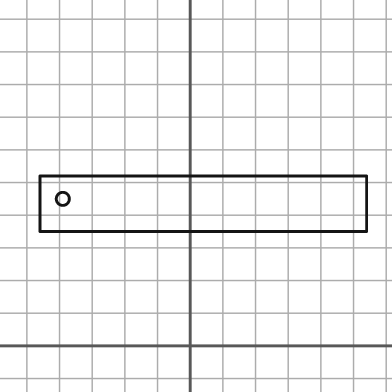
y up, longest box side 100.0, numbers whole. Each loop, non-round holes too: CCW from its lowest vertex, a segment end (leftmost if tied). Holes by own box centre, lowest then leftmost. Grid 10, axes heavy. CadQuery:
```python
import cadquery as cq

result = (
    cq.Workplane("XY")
    .moveTo(-46.0, 35.0)
    .lineTo(54.0, 35.0)
    .lineTo(54.0, 52.0)
    .lineTo(-46.0, 52.0)
    .close()
    .moveTo(-39.0, 45.0)
    .circle(2.0)
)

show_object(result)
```